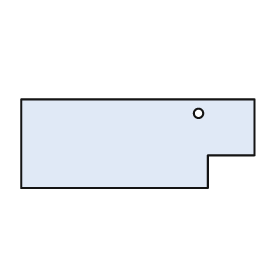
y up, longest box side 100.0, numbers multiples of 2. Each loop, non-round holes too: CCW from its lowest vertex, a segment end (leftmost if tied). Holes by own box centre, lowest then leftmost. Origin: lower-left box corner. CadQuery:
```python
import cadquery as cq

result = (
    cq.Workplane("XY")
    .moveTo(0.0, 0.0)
    .lineTo(80.0, 0.0)
    .lineTo(80.0, 14.0)
    .lineTo(100.0, 14.0)
    .lineTo(100.0, 38.0)
    .lineTo(0.0, 38.0)
    .close()
    .moveTo(76.0, 32.0)
    .circle(2.0)
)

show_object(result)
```